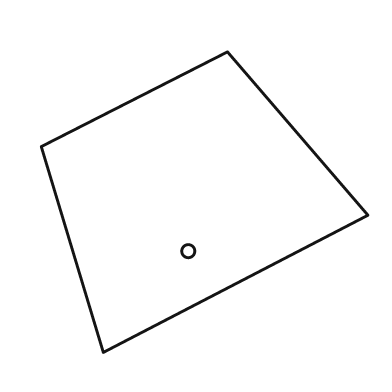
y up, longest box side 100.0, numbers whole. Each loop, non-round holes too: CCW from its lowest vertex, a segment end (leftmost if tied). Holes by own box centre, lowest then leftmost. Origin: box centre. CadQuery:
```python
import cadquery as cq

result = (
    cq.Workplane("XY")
    .moveTo(-31.0, -46.0)
    .lineTo(50.0, -4.0)
    .lineTo(7.0, 46.0)
    .lineTo(-50.0, 17.0)
    .close()
    .moveTo(-5.0, -15.0)
    .circle(2.0)
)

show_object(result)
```